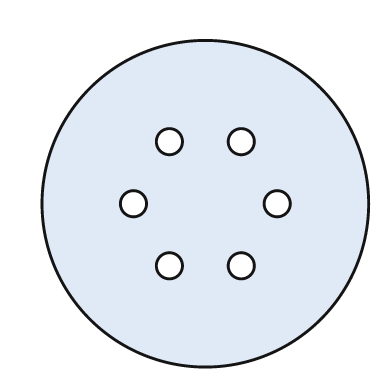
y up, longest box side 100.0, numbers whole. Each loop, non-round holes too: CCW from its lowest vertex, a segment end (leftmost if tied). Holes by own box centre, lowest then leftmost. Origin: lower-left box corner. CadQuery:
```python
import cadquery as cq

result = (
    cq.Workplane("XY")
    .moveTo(50.0, 50.0)
    .circle(50.0)
    .moveTo(39.0, 31.0)
    .circle(4.0)
    .moveTo(61.0, 31.0)
    .circle(4.0)
    .moveTo(28.0, 50.0)
    .circle(4.0)
    .moveTo(72.0, 50.0)
    .circle(4.0)
    .moveTo(39.0, 69.0)
    .circle(4.0)
    .moveTo(61.0, 69.0)
    .circle(4.0)
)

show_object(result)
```